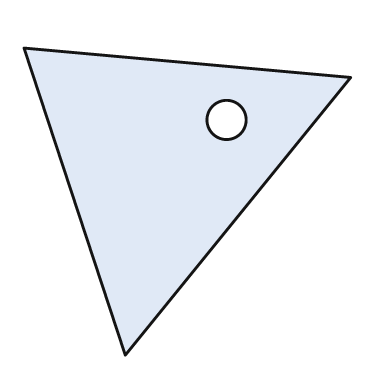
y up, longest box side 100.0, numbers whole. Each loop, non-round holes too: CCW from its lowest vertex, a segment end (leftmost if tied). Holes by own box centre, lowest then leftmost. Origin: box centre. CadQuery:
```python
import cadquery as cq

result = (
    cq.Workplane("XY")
    .moveTo(-19.0, -47.0)
    .lineTo(50.0, 38.0)
    .lineTo(-50.0, 47.0)
    .close()
    .moveTo(12.0, 25.0)
    .circle(6.0)
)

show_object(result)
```